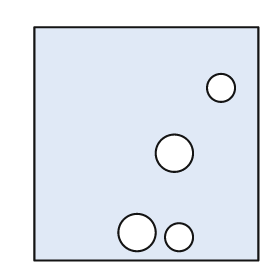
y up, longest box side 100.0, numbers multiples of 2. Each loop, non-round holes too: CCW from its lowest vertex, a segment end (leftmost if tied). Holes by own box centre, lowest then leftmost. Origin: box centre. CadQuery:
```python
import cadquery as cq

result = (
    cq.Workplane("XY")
    .moveTo(-48.0, -50.0)
    .lineTo(48.0, -50.0)
    .lineTo(48.0, 50.0)
    .lineTo(-48.0, 50.0)
    .close()
    .moveTo(14.0, -40.0)
    .circle(6.0)
    .moveTo(-4.0, -38.0)
    .circle(8.0)
    .moveTo(12.0, -4.0)
    .circle(8.0)
    .moveTo(32.0, 24.0)
    .circle(6.0)
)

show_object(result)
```